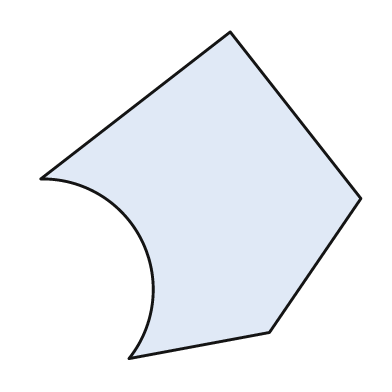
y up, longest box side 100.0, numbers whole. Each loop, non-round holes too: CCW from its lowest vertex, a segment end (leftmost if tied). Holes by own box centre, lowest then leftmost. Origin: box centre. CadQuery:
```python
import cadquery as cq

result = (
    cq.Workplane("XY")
    .moveTo(-22.0, -50.0)
    .lineTo(21.0, -42.0)
    .lineTo(49.0, -1.0)
    .lineTo(9.0, 50.0)
    .lineTo(-49.0, 5.0)
    .threePointArc((-18.0, -14.0), (-22.0, -50.0))
    .close()
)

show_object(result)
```